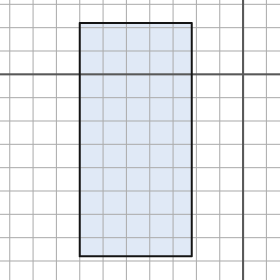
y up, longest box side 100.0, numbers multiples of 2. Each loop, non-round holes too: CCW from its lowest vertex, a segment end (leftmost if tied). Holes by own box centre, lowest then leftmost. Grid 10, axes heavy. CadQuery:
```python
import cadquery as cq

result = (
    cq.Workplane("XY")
    .moveTo(-70.0, -78.0)
    .lineTo(-22.0, -78.0)
    .lineTo(-22.0, 22.0)
    .lineTo(-70.0, 22.0)
    .close()
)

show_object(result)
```